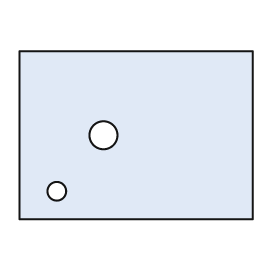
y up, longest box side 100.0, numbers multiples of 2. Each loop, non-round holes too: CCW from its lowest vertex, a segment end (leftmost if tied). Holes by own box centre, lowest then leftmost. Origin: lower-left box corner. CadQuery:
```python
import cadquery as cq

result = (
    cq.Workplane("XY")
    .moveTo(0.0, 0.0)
    .lineTo(100.0, 0.0)
    .lineTo(100.0, 72.0)
    .lineTo(0.0, 72.0)
    .close()
    .moveTo(16.0, 12.0)
    .circle(4.0)
    .moveTo(36.0, 36.0)
    .circle(6.0)
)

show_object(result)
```